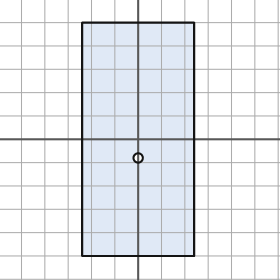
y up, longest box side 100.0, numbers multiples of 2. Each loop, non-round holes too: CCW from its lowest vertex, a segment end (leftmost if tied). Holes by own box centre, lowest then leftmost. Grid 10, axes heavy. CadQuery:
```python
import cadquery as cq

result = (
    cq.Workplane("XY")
    .moveTo(-24.0, -50.0)
    .lineTo(24.0, -50.0)
    .lineTo(24.0, 50.0)
    .lineTo(-24.0, 50.0)
    .close()
    .moveTo(0.0, -8.0)
    .circle(2.0)
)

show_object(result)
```